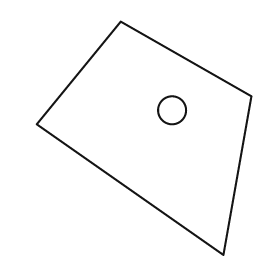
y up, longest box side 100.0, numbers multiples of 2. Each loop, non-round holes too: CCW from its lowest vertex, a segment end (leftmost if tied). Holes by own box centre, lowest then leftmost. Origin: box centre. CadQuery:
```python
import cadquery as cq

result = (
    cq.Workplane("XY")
    .moveTo(34.0, -50.0)
    .lineTo(46.0, 18.0)
    .lineTo(-10.0, 50.0)
    .lineTo(-46.0, 6.0)
    .close()
    .moveTo(12.0, 12.0)
    .circle(6.0)
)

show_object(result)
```